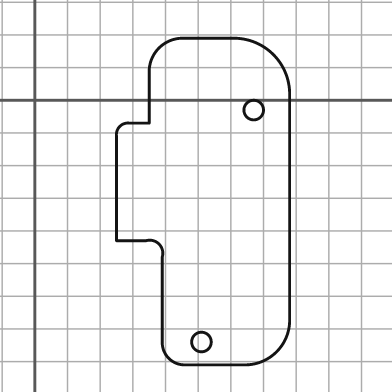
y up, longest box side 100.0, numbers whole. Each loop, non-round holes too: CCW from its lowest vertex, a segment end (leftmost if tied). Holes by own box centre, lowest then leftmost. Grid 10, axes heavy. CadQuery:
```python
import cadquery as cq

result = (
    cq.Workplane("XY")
    .moveTo(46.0, -81.0)
    .lineTo(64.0, -81.0)
    .threePointArc((74.0, -77.0), (78.0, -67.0))
    .lineTo(78.0, 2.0)
    .threePointArc((73.0, 14.0), (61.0, 19.0))
    .lineTo(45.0, 19.0)
    .threePointArc((38.0, 16.0), (35.0, 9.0))
    .lineTo(35.0, -7.0)
    .lineTo(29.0, -7.0)
    .threePointArc((26.0, -8.0), (25.0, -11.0))
    .lineTo(25.0, -43.0)
    .lineTo(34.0, -43.0)
    .threePointArc((38.0, -44.0), (39.0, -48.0))
    .lineTo(39.0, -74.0)
    .threePointArc((41.0, -79.0), (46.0, -81.0))
    .close()
    .moveTo(51.0, -74.0)
    .circle(3.0)
    .moveTo(67.0, -3.0)
    .circle(3.0)
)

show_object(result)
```